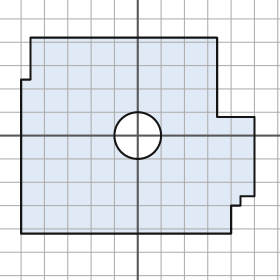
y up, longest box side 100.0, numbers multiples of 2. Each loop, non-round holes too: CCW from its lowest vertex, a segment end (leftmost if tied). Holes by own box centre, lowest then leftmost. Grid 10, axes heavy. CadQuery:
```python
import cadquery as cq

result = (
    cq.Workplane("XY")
    .moveTo(-50.0, -42.0)
    .lineTo(40.0, -42.0)
    .lineTo(40.0, -30.0)
    .lineTo(44.0, -30.0)
    .lineTo(44.0, -26.0)
    .lineTo(50.0, -26.0)
    .lineTo(50.0, 8.0)
    .lineTo(34.0, 8.0)
    .lineTo(34.0, 42.0)
    .lineTo(-46.0, 42.0)
    .lineTo(-46.0, 24.0)
    .lineTo(-50.0, 24.0)
    .close()
    .moveTo(0.0, 0.0)
    .circle(10.0)
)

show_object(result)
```